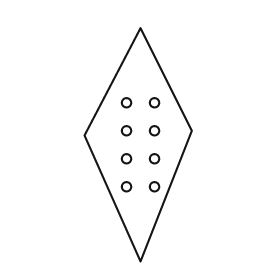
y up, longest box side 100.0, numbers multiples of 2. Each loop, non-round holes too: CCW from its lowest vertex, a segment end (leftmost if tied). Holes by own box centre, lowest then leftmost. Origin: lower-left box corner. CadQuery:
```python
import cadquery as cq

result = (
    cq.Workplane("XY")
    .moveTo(24.0, 0.0)
    .lineTo(46.0, 56.0)
    .lineTo(24.0, 100.0)
    .lineTo(0.0, 54.0)
    .close()
    .moveTo(18.0, 32.0)
    .circle(2.0)
    .moveTo(30.0, 32.0)
    .circle(2.0)
    .moveTo(18.0, 44.0)
    .circle(2.0)
    .moveTo(30.0, 44.0)
    .circle(2.0)
    .moveTo(18.0, 56.0)
    .circle(2.0)
    .moveTo(30.0, 56.0)
    .circle(2.0)
    .moveTo(18.0, 68.0)
    .circle(2.0)
    .moveTo(30.0, 68.0)
    .circle(2.0)
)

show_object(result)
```